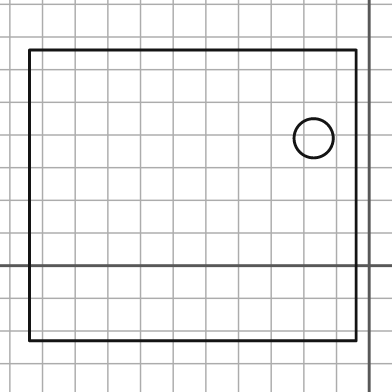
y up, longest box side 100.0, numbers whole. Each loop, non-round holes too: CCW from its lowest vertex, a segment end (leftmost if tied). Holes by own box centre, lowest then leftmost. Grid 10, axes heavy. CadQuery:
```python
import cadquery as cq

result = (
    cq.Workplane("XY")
    .moveTo(-104.0, -23.0)
    .lineTo(-4.0, -23.0)
    .lineTo(-4.0, 66.0)
    .lineTo(-104.0, 66.0)
    .close()
    .moveTo(-17.0, 39.0)
    .circle(6.0)
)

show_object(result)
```